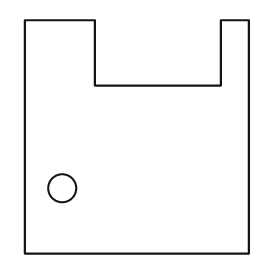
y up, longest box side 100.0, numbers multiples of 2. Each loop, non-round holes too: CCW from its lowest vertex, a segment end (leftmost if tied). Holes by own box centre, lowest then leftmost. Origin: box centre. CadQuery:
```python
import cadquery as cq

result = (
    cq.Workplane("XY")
    .moveTo(-48.0, -50.0)
    .lineTo(48.0, -50.0)
    .lineTo(48.0, 50.0)
    .lineTo(36.0, 50.0)
    .lineTo(36.0, 22.0)
    .lineTo(-18.0, 22.0)
    .lineTo(-18.0, 50.0)
    .lineTo(-48.0, 50.0)
    .close()
    .moveTo(-32.0, -22.0)
    .circle(6.0)
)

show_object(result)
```